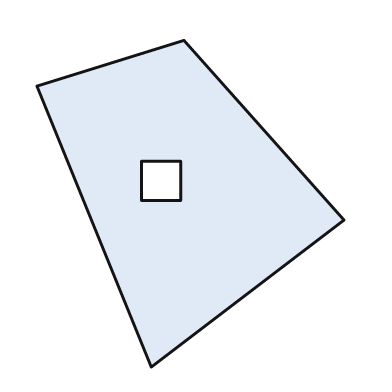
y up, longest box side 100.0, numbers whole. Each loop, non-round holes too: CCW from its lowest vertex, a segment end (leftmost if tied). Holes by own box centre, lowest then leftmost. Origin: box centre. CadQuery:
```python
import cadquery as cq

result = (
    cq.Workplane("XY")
    .moveTo(-12.0, -50.0)
    .lineTo(47.0, -5.0)
    .lineTo(-2.0, 50.0)
    .lineTo(-47.0, 36.0)
    .close()
    .moveTo(-15.0, 1.0)
    .lineTo(-3.0, 1.0)
    .lineTo(-3.0, 13.0)
    .lineTo(-15.0, 13.0)
    .close()
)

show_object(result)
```